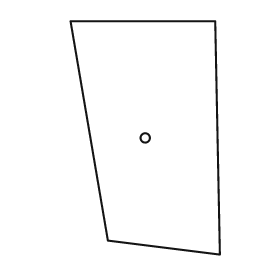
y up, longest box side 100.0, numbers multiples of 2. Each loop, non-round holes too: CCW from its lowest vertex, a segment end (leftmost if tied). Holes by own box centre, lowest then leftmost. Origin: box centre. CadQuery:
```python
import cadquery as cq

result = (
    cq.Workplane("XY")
    .moveTo(32.0, -50.0)
    .lineTo(30.0, 50.0)
    .lineTo(-32.0, 50.0)
    .lineTo(-16.0, -44.0)
    .close()
    .moveTo(0.0, 0.0)
    .circle(2.0)
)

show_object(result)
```